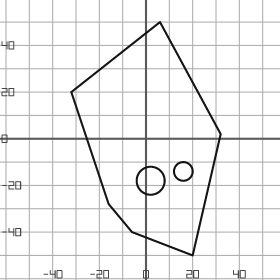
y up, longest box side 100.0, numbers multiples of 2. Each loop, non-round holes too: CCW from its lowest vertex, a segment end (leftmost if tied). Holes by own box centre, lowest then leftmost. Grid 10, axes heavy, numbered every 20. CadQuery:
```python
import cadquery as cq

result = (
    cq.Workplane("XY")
    .moveTo(20.0, -50.0)
    .lineTo(32.0, 2.0)
    .lineTo(6.0, 50.0)
    .lineTo(-32.0, 20.0)
    .lineTo(-16.0, -28.0)
    .lineTo(-6.0, -40.0)
    .close()
    .moveTo(2.0, -18.0)
    .circle(6.0)
    .moveTo(16.0, -14.0)
    .circle(4.0)
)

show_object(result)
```